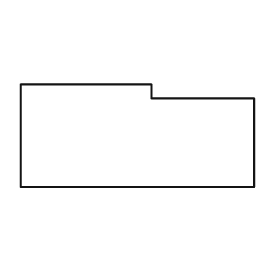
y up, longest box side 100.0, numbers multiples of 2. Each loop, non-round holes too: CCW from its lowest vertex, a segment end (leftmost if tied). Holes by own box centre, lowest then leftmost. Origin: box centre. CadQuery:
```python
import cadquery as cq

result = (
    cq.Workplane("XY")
    .moveTo(-50.0, -22.0)
    .lineTo(50.0, -22.0)
    .lineTo(50.0, 16.0)
    .lineTo(6.0, 16.0)
    .lineTo(6.0, 22.0)
    .lineTo(-50.0, 22.0)
    .close()
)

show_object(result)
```